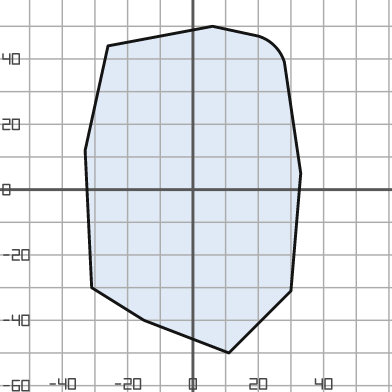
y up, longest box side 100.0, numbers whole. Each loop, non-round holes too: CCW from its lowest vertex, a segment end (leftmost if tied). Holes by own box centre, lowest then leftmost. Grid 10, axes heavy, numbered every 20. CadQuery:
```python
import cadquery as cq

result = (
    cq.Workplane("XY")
    .moveTo(11.0, -50.0)
    .lineTo(30.0, -31.0)
    .lineTo(33.0, 5.0)
    .lineTo(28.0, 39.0)
    .threePointArc((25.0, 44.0), (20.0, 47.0))
    .lineTo(6.0, 50.0)
    .lineTo(-26.0, 44.0)
    .lineTo(-33.0, 12.0)
    .lineTo(-31.0, -30.0)
    .lineTo(-15.0, -40.0)
    .close()
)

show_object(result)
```